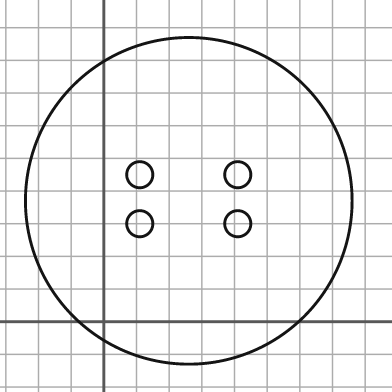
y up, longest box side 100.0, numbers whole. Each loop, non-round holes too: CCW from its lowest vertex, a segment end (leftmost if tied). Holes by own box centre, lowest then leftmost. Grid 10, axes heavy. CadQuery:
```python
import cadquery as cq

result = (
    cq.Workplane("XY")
    .moveTo(26.0, 37.0)
    .circle(50.0)
    .moveTo(11.0, 30.0)
    .circle(4.0)
    .moveTo(41.0, 30.0)
    .circle(4.0)
    .moveTo(11.0, 45.0)
    .circle(4.0)
    .moveTo(41.0, 45.0)
    .circle(4.0)
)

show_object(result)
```